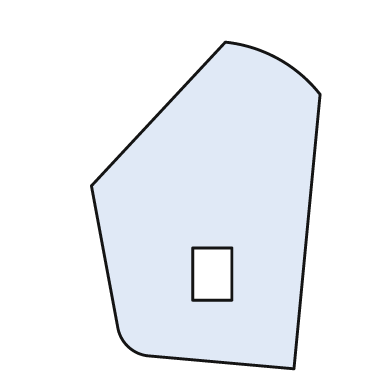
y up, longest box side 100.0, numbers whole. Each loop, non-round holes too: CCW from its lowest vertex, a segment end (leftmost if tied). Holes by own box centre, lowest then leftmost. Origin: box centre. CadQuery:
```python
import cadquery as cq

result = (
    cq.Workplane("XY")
    .moveTo(27.0, -50.0)
    .lineTo(35.0, 34.0)
    .threePointArc((22.0, 45.0), (6.0, 50.0))
    .lineTo(-35.0, 6.0)
    .lineTo(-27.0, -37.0)
    .threePointArc((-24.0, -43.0), (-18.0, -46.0))
    .close()
    .moveTo(-4.0, -29.0)
    .lineTo(8.0, -29.0)
    .lineTo(8.0, -13.0)
    .lineTo(-4.0, -13.0)
    .close()
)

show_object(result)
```